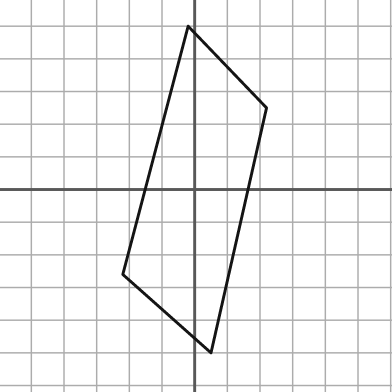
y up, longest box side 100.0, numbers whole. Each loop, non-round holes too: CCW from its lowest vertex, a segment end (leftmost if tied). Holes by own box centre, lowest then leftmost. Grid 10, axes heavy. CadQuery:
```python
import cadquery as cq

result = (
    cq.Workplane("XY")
    .moveTo(5.0, -50.0)
    .lineTo(22.0, 25.0)
    .lineTo(-2.0, 50.0)
    .lineTo(-22.0, -26.0)
    .close()
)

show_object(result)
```